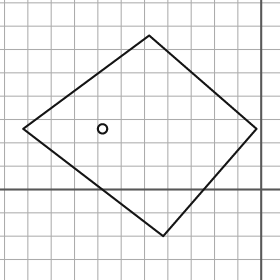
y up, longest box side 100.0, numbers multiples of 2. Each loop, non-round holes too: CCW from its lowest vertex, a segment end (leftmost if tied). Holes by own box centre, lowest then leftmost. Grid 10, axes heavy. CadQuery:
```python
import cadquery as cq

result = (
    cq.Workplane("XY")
    .moveTo(-42.0, -20.0)
    .lineTo(-2.0, 26.0)
    .lineTo(-48.0, 66.0)
    .lineTo(-102.0, 26.0)
    .close()
    .moveTo(-68.0, 26.0)
    .circle(2.0)
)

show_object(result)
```